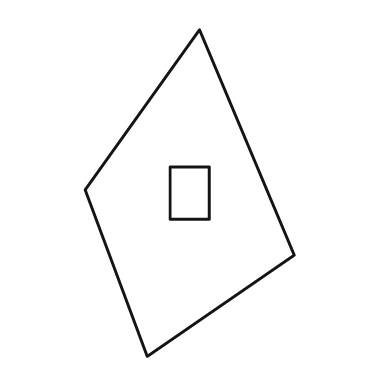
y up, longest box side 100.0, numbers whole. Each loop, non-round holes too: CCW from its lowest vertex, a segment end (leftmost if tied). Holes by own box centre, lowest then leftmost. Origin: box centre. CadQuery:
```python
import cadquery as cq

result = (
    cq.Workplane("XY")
    .moveTo(-13.0, -50.0)
    .lineTo(32.0, -19.0)
    .lineTo(3.0, 50.0)
    .lineTo(-32.0, 1.0)
    .close()
    .moveTo(-6.0, -8.0)
    .lineTo(6.0, -8.0)
    .lineTo(6.0, 8.0)
    .lineTo(-6.0, 8.0)
    .close()
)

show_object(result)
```